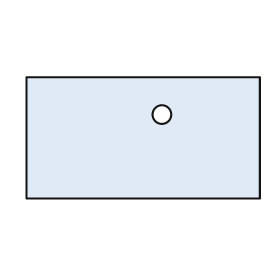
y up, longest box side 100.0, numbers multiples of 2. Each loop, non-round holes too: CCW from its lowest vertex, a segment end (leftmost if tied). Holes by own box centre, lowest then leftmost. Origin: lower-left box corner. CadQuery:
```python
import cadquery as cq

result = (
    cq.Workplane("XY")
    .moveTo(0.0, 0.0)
    .lineTo(100.0, 0.0)
    .lineTo(100.0, 52.0)
    .lineTo(0.0, 52.0)
    .close()
    .moveTo(58.0, 36.0)
    .circle(4.0)
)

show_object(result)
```